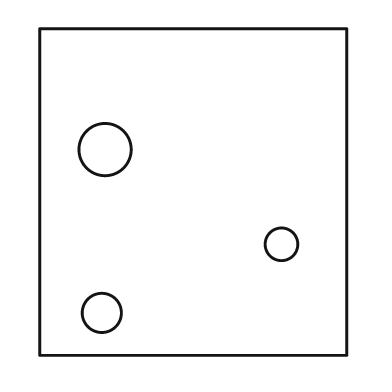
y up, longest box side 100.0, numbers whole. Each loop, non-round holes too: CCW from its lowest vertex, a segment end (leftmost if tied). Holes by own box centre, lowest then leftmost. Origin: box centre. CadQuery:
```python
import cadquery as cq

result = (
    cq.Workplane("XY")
    .moveTo(-47.0, -50.0)
    .lineTo(47.0, -50.0)
    .lineTo(47.0, 50.0)
    .lineTo(-47.0, 50.0)
    .close()
    .moveTo(-28.0, -37.0)
    .circle(6.0)
    .moveTo(27.0, -16.0)
    .circle(5.0)
    .moveTo(-27.0, 13.0)
    .circle(8.0)
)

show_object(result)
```